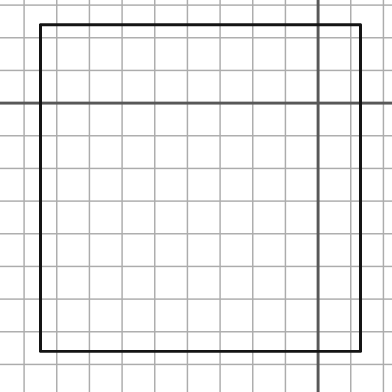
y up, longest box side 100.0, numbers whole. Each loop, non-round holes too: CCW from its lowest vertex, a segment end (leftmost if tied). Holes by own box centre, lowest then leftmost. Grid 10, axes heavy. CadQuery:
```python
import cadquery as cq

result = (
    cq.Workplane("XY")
    .moveTo(-85.0, -76.0)
    .lineTo(13.0, -76.0)
    .lineTo(13.0, 24.0)
    .lineTo(-85.0, 24.0)
    .close()
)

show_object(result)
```